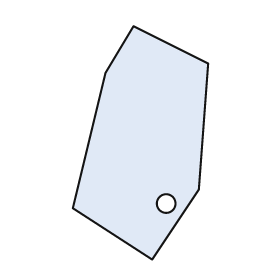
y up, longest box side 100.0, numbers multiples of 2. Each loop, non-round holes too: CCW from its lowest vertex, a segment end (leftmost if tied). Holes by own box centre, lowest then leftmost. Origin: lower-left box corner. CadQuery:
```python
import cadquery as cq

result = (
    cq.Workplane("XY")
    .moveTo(34.0, 0.0)
    .lineTo(54.0, 30.0)
    .lineTo(58.0, 84.0)
    .lineTo(26.0, 100.0)
    .lineTo(14.0, 80.0)
    .lineTo(0.0, 22.0)
    .close()
    .moveTo(40.0, 24.0)
    .circle(4.0)
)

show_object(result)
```